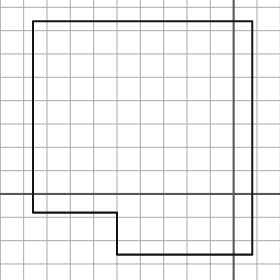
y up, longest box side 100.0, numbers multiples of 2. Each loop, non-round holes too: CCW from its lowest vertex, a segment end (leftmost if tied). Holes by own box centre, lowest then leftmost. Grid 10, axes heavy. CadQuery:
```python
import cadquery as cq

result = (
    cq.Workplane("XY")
    .moveTo(-50.0, -26.0)
    .lineTo(8.0, -26.0)
    .lineTo(8.0, 74.0)
    .lineTo(-86.0, 74.0)
    .lineTo(-86.0, -8.0)
    .lineTo(-50.0, -8.0)
    .close()
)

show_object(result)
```